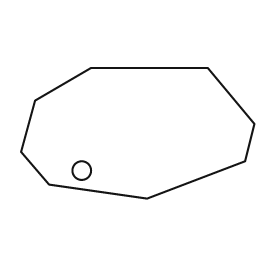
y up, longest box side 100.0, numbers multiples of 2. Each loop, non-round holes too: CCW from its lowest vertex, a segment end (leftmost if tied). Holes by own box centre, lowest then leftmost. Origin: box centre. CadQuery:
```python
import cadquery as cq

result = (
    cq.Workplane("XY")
    .moveTo(4.0, -28.0)
    .lineTo(46.0, -12.0)
    .lineTo(50.0, 4.0)
    .lineTo(30.0, 28.0)
    .lineTo(-20.0, 28.0)
    .lineTo(-44.0, 14.0)
    .lineTo(-50.0, -8.0)
    .lineTo(-38.0, -22.0)
    .close()
    .moveTo(-24.0, -16.0)
    .circle(4.0)
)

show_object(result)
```